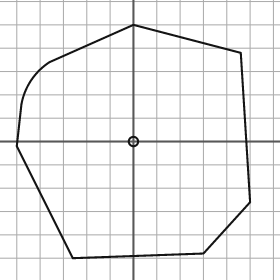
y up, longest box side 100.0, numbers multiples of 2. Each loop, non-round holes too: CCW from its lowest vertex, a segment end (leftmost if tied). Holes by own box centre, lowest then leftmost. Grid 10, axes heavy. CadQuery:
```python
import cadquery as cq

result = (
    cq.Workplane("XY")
    .moveTo(-26.0, -50.0)
    .lineTo(30.0, -48.0)
    .lineTo(50.0, -26.0)
    .lineTo(46.0, 38.0)
    .lineTo(0.0, 50.0)
    .lineTo(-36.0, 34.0)
    .threePointArc((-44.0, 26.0), (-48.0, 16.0))
    .lineTo(-50.0, -2.0)
    .close()
    .moveTo(0.0, 0.0)
    .circle(2.0)
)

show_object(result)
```